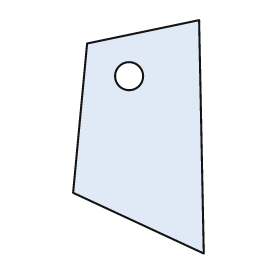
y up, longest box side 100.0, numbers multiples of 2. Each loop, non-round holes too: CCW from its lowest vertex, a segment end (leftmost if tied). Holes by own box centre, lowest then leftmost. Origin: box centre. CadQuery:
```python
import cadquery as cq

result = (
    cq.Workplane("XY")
    .moveTo(28.0, -50.0)
    .lineTo(26.0, 50.0)
    .lineTo(-22.0, 40.0)
    .lineTo(-28.0, -24.0)
    .close()
    .moveTo(-4.0, 26.0)
    .circle(6.0)
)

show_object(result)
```